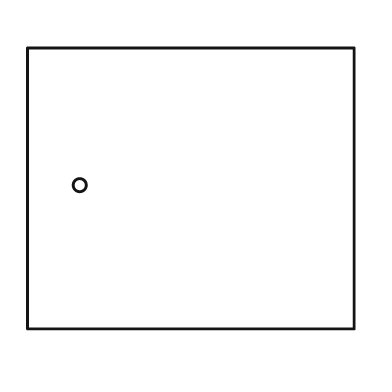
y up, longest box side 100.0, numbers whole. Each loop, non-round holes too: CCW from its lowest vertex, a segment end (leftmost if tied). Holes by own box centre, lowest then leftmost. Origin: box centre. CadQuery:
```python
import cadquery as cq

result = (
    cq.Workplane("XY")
    .moveTo(-50.0, -43.0)
    .lineTo(50.0, -43.0)
    .lineTo(50.0, 43.0)
    .lineTo(-50.0, 43.0)
    .close()
    .moveTo(-34.0, 1.0)
    .circle(2.0)
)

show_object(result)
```